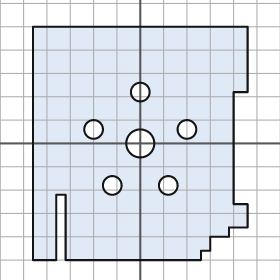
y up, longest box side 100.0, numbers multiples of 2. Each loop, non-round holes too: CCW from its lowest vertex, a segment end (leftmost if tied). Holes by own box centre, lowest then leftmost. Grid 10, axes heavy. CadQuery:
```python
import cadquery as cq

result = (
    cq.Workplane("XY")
    .moveTo(-46.0, -50.0)
    .lineTo(-36.0, -50.0)
    .lineTo(-36.0, -22.0)
    .lineTo(-32.0, -22.0)
    .lineTo(-32.0, -50.0)
    .lineTo(26.0, -50.0)
    .lineTo(26.0, -46.0)
    .lineTo(30.0, -46.0)
    .lineTo(30.0, -40.0)
    .lineTo(38.0, -40.0)
    .lineTo(38.0, -36.0)
    .lineTo(46.0, -36.0)
    .lineTo(46.0, -26.0)
    .lineTo(40.0, -26.0)
    .lineTo(40.0, 22.0)
    .lineTo(46.0, 22.0)
    .lineTo(46.0, 50.0)
    .lineTo(-46.0, 50.0)
    .close()
    .moveTo(-12.0, -18.0)
    .circle(4.0)
    .moveTo(12.0, -18.0)
    .circle(4.0)
    .moveTo(0.0, 0.0)
    .circle(6.0)
    .moveTo(-20.0, 6.0)
    .circle(4.0)
    .moveTo(20.0, 6.0)
    .circle(4.0)
    .moveTo(0.0, 22.0)
    .circle(4.0)
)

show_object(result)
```